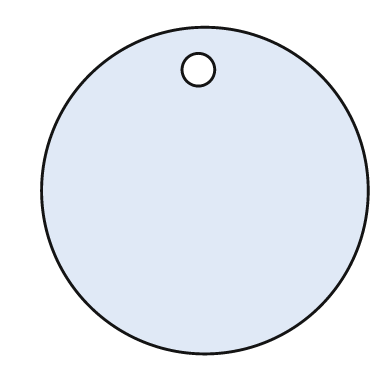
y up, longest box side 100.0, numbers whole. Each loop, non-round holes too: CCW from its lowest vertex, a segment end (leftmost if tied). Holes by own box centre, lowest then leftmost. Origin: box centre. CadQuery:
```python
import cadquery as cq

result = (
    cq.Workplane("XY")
    .moveTo(0.0, 0.0)
    .circle(50.0)
    .moveTo(-2.0, 37.0)
    .circle(5.0)
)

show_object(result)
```